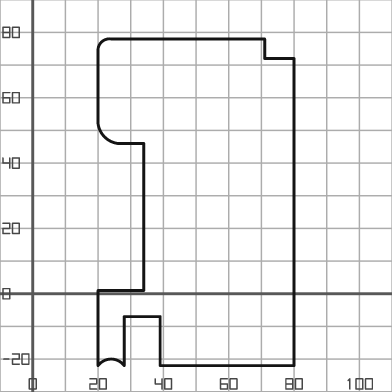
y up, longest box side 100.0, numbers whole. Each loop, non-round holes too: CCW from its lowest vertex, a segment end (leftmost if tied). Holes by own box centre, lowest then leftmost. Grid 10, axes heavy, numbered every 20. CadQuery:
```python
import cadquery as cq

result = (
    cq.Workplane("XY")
    .moveTo(20.0, -22.0)
    .threePointArc((24.0, -20.0), (28.0, -22.0))
    .lineTo(28.0, -7.0)
    .lineTo(39.0, -7.0)
    .lineTo(39.0, -22.0)
    .lineTo(80.0, -22.0)
    .lineTo(80.0, 72.0)
    .lineTo(71.0, 72.0)
    .lineTo(71.0, 78.0)
    .lineTo(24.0, 78.0)
    .threePointArc((21.0, 77.0), (20.0, 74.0))
    .lineTo(20.0, 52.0)
    .threePointArc((22.0, 48.0), (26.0, 46.0))
    .lineTo(34.0, 46.0)
    .lineTo(34.0, 1.0)
    .lineTo(20.0, 1.0)
    .close()
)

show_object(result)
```